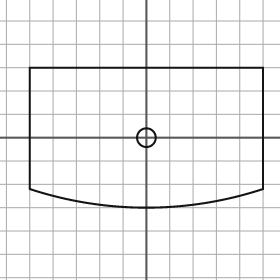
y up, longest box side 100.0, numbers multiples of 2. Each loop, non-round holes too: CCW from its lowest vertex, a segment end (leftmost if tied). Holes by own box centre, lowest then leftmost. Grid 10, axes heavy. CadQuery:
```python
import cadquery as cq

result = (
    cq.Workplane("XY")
    .moveTo(-50.0, -22.0)
    .threePointArc((0.0, -30.0), (50.0, -22.0))
    .lineTo(50.0, 30.0)
    .lineTo(-50.0, 30.0)
    .close()
    .moveTo(0.0, 0.0)
    .circle(4.0)
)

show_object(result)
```